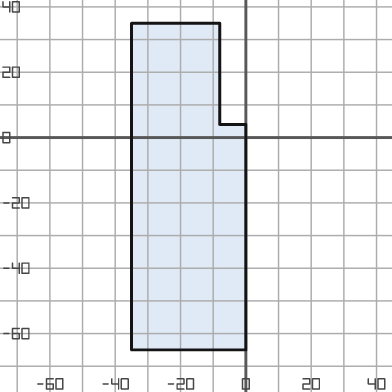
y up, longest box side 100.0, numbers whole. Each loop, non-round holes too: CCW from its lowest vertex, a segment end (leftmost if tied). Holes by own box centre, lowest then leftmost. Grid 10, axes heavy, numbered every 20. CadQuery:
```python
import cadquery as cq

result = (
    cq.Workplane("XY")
    .moveTo(-35.0, -65.0)
    .lineTo(0.0, -65.0)
    .lineTo(0.0, 4.0)
    .lineTo(-8.0, 4.0)
    .lineTo(-8.0, 35.0)
    .lineTo(-35.0, 35.0)
    .close()
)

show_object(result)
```